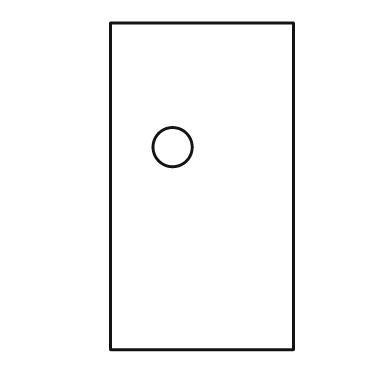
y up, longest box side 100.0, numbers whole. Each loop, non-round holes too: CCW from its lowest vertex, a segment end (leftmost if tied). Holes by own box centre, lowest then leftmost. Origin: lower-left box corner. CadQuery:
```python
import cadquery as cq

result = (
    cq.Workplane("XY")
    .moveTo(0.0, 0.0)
    .lineTo(56.0, 0.0)
    .lineTo(56.0, 100.0)
    .lineTo(0.0, 100.0)
    .close()
    .moveTo(19.0, 62.0)
    .circle(6.0)
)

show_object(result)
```